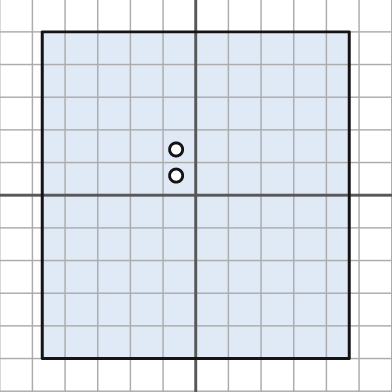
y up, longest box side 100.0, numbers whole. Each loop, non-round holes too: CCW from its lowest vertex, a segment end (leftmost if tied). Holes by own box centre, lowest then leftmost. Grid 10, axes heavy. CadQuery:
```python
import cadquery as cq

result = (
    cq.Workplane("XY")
    .moveTo(-47.0, -50.0)
    .lineTo(47.0, -50.0)
    .lineTo(47.0, 50.0)
    .lineTo(-47.0, 50.0)
    .close()
    .moveTo(-6.0, 6.0)
    .circle(2.0)
    .moveTo(-6.0, 14.0)
    .circle(2.0)
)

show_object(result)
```